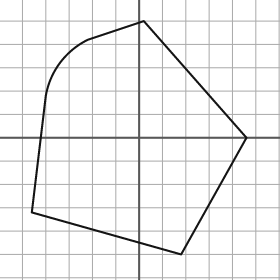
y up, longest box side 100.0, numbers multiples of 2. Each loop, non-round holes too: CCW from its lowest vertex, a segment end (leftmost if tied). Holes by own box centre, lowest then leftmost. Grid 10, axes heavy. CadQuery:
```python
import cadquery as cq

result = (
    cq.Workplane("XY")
    .moveTo(18.0, -50.0)
    .lineTo(46.0, 0.0)
    .lineTo(2.0, 50.0)
    .lineTo(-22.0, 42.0)
    .threePointArc((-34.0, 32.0), (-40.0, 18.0))
    .lineTo(-46.0, -32.0)
    .close()
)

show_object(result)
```